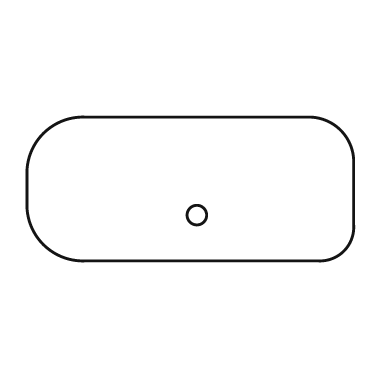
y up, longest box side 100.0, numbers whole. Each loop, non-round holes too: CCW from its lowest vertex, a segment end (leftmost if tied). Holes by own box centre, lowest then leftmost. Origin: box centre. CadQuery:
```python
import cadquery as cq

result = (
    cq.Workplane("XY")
    .moveTo(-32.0, -22.0)
    .lineTo(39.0, -22.0)
    .threePointArc((47.0, -19.0), (50.0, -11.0))
    .lineTo(50.0, 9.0)
    .threePointArc((46.0, 18.0), (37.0, 22.0))
    .lineTo(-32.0, 22.0)
    .threePointArc((-45.0, 17.0), (-50.0, 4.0))
    .lineTo(-50.0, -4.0)
    .threePointArc((-45.0, -17.0), (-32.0, -22.0))
    .close()
    .moveTo(2.0, -8.0)
    .circle(3.0)
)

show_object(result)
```